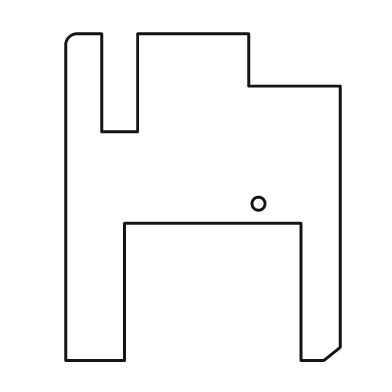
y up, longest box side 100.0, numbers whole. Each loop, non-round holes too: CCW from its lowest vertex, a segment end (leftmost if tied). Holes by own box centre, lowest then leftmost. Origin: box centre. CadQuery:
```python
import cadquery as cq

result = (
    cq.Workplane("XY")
    .moveTo(-42.0, -50.0)
    .lineTo(-24.0, -50.0)
    .lineTo(-24.0, -8.0)
    .lineTo(30.0, -8.0)
    .lineTo(30.0, -50.0)
    .lineTo(37.0, -50.0)
    .lineTo(42.0, -46.0)
    .lineTo(42.0, 34.0)
    .lineTo(14.0, 34.0)
    .lineTo(14.0, 50.0)
    .lineTo(-20.0, 50.0)
    .lineTo(-20.0, 20.0)
    .lineTo(-31.0, 20.0)
    .lineTo(-31.0, 50.0)
    .lineTo(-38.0, 50.0)
    .threePointArc((-41.0, 49.0), (-42.0, 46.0))
    .close()
    .moveTo(17.0, -2.0)
    .circle(2.0)
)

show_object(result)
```